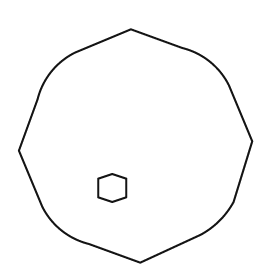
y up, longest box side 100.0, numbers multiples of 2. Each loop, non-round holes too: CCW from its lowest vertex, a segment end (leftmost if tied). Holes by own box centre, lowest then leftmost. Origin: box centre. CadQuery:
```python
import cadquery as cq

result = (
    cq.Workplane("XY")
    .moveTo(2.0, -50.0)
    .lineTo(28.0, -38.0)
    .threePointArc((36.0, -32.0), (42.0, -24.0))
    .lineTo(50.0, 2.0)
    .lineTo(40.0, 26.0)
    .threePointArc((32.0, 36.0), (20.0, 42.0))
    .lineTo(-2.0, 50.0)
    .lineTo(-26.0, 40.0)
    .threePointArc((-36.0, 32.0), (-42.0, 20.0))
    .lineTo(-50.0, -2.0)
    .lineTo(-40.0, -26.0)
    .threePointArc((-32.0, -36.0), (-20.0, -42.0))
    .close()
    .moveTo(-10.0, -24.0)
    .lineTo(-4.0, -22.0)
    .lineTo(-4.0, -14.0)
    .lineTo(-10.0, -12.0)
    .lineTo(-16.0, -14.0)
    .lineTo(-16.0, -22.0)
    .close()
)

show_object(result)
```